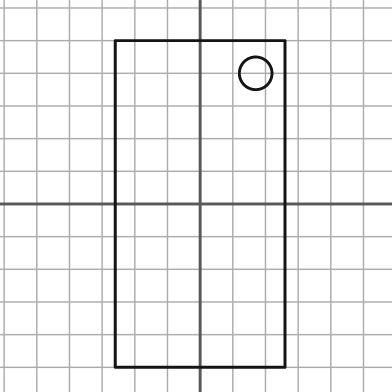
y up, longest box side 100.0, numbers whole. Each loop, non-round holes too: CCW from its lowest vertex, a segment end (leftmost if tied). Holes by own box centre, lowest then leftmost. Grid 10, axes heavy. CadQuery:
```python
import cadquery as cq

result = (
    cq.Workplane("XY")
    .moveTo(-26.0, -50.0)
    .lineTo(26.0, -50.0)
    .lineTo(26.0, 50.0)
    .lineTo(-26.0, 50.0)
    .close()
    .moveTo(17.0, 40.0)
    .circle(5.0)
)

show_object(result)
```